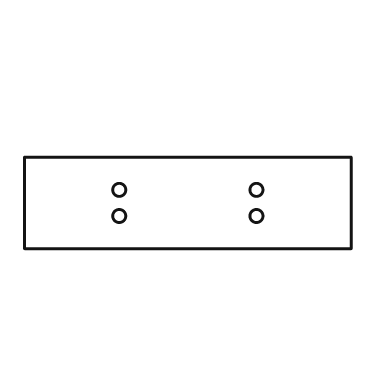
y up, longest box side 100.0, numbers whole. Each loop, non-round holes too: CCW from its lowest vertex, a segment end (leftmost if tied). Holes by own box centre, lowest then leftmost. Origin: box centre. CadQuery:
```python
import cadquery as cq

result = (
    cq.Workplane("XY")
    .moveTo(-50.0, -14.0)
    .lineTo(50.0, -14.0)
    .lineTo(50.0, 14.0)
    .lineTo(-50.0, 14.0)
    .close()
    .moveTo(-21.0, -4.0)
    .circle(2.0)
    .moveTo(21.0, -4.0)
    .circle(2.0)
    .moveTo(-21.0, 4.0)
    .circle(2.0)
    .moveTo(21.0, 4.0)
    .circle(2.0)
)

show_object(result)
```